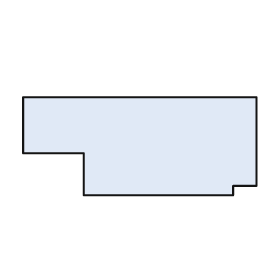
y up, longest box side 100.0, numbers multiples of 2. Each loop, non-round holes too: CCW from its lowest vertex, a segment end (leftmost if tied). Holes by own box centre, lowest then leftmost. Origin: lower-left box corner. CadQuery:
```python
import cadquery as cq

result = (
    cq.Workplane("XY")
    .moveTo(26.0, 0.0)
    .lineTo(90.0, 0.0)
    .lineTo(90.0, 4.0)
    .lineTo(100.0, 4.0)
    .lineTo(100.0, 42.0)
    .lineTo(0.0, 42.0)
    .lineTo(0.0, 18.0)
    .lineTo(26.0, 18.0)
    .close()
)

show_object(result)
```